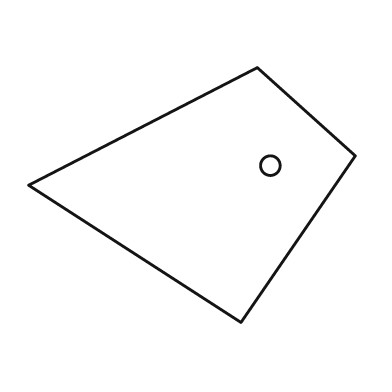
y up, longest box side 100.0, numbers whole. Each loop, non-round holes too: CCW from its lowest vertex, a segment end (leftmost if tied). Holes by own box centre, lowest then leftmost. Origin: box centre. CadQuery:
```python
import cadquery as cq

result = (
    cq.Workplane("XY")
    .moveTo(15.0, -39.0)
    .lineTo(50.0, 12.0)
    .lineTo(20.0, 39.0)
    .lineTo(-50.0, 3.0)
    .close()
    .moveTo(24.0, 9.0)
    .circle(3.0)
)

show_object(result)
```